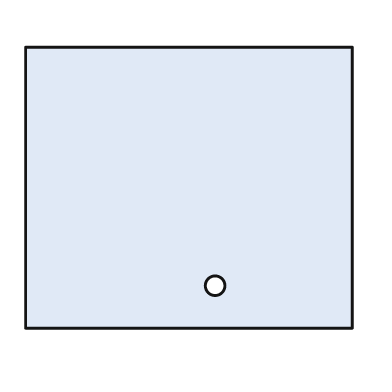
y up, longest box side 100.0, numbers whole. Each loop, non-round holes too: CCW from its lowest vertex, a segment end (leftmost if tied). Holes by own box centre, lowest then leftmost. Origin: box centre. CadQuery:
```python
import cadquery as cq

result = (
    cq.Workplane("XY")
    .moveTo(-50.0, -43.0)
    .lineTo(50.0, -43.0)
    .lineTo(50.0, 43.0)
    .lineTo(-50.0, 43.0)
    .close()
    .moveTo(8.0, -30.0)
    .circle(3.0)
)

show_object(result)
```